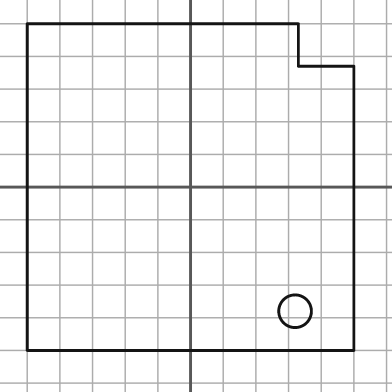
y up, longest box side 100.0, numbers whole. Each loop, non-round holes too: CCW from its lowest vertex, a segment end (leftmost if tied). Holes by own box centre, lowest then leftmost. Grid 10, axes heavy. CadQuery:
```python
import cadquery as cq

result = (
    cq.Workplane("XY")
    .moveTo(-50.0, -50.0)
    .lineTo(50.0, -50.0)
    .lineTo(50.0, 37.0)
    .lineTo(33.0, 37.0)
    .lineTo(33.0, 50.0)
    .lineTo(-50.0, 50.0)
    .close()
    .moveTo(32.0, -38.0)
    .circle(5.0)
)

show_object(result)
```